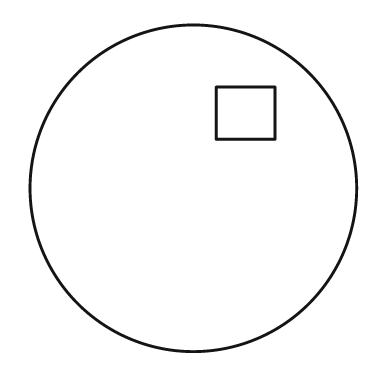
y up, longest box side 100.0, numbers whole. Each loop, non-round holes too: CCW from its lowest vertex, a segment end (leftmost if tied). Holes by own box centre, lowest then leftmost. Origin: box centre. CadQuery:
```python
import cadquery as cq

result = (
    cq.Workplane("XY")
    .moveTo(0.0, 0.0)
    .circle(50.0)
    .moveTo(7.0, 15.0)
    .lineTo(25.0, 15.0)
    .lineTo(25.0, 31.0)
    .lineTo(7.0, 31.0)
    .close()
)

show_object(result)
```